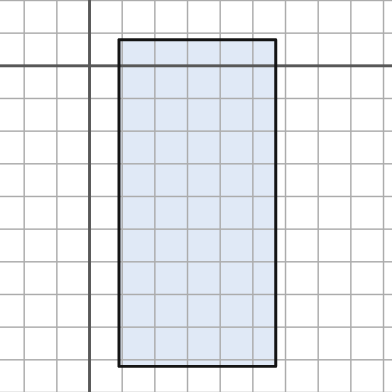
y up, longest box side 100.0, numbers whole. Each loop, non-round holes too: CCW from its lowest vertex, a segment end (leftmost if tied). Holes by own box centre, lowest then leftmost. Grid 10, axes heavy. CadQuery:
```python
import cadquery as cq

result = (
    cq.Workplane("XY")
    .moveTo(9.0, -92.0)
    .lineTo(57.0, -92.0)
    .lineTo(57.0, 8.0)
    .lineTo(9.0, 8.0)
    .close()
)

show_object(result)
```